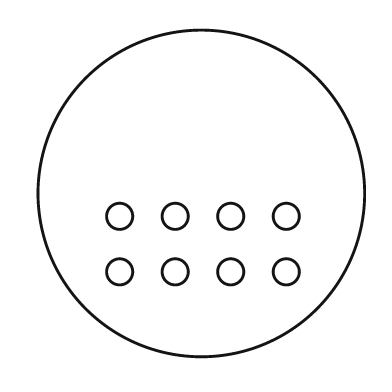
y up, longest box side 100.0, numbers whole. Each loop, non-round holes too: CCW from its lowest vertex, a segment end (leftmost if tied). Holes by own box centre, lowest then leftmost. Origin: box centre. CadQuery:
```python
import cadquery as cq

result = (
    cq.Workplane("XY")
    .moveTo(0.0, 0.0)
    .circle(50.0)
    .moveTo(-25.0, -24.0)
    .circle(4.0)
    .moveTo(-8.0, -24.0)
    .circle(4.0)
    .moveTo(9.0, -24.0)
    .circle(4.0)
    .moveTo(26.0, -24.0)
    .circle(4.0)
    .moveTo(-25.0, -7.0)
    .circle(4.0)
    .moveTo(-8.0, -7.0)
    .circle(4.0)
    .moveTo(9.0, -7.0)
    .circle(4.0)
    .moveTo(26.0, -7.0)
    .circle(4.0)
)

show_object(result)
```